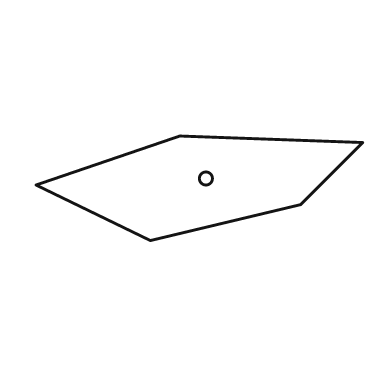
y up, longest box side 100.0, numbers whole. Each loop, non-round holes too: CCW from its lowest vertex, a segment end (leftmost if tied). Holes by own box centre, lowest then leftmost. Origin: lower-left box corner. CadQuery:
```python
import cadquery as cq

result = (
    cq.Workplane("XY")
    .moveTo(35.0, 0.0)
    .lineTo(81.0, 11.0)
    .lineTo(100.0, 30.0)
    .lineTo(44.0, 32.0)
    .lineTo(0.0, 17.0)
    .close()
    .moveTo(52.0, 19.0)
    .circle(2.0)
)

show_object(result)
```